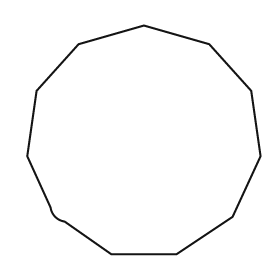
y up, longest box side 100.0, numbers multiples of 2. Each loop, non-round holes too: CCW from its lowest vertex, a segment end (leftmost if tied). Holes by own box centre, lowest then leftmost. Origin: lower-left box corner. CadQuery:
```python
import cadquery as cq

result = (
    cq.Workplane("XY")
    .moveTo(36.0, 0.0)
    .lineTo(64.0, 0.0)
    .lineTo(88.0, 16.0)
    .lineTo(100.0, 42.0)
    .lineTo(96.0, 70.0)
    .lineTo(78.0, 90.0)
    .lineTo(50.0, 98.0)
    .lineTo(22.0, 90.0)
    .lineTo(4.0, 70.0)
    .lineTo(0.0, 42.0)
    .lineTo(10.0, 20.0)
    .threePointArc((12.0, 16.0), (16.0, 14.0))
    .close()
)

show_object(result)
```